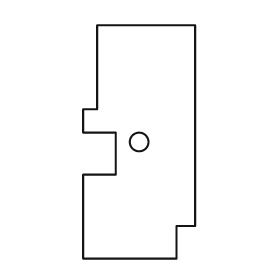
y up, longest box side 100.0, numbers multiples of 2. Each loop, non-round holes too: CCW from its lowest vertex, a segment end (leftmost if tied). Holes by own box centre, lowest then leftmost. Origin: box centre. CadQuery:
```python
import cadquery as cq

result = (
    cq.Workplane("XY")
    .moveTo(-24.0, -50.0)
    .lineTo(16.0, -50.0)
    .lineTo(16.0, -36.0)
    .lineTo(24.0, -36.0)
    .lineTo(24.0, 50.0)
    .lineTo(-18.0, 50.0)
    .lineTo(-18.0, 14.0)
    .lineTo(-24.0, 14.0)
    .lineTo(-24.0, 4.0)
    .lineTo(-10.0, 4.0)
    .lineTo(-10.0, -14.0)
    .lineTo(-24.0, -14.0)
    .close()
    .moveTo(0.0, 0.0)
    .circle(4.0)
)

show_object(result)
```